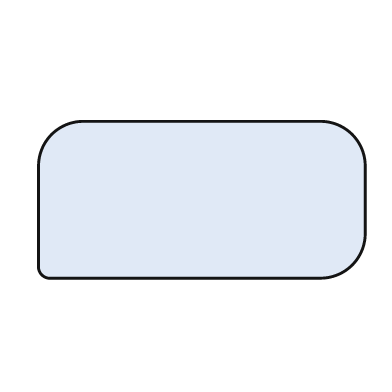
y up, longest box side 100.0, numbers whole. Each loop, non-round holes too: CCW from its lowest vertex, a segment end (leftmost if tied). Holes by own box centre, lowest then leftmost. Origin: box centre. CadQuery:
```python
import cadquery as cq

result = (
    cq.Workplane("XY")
    .moveTo(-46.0, -24.0)
    .lineTo(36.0, -24.0)
    .threePointArc((46.0, -20.0), (50.0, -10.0))
    .lineTo(50.0, 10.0)
    .threePointArc((46.0, 20.0), (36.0, 24.0))
    .lineTo(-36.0, 24.0)
    .threePointArc((-46.0, 20.0), (-50.0, 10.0))
    .lineTo(-50.0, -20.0)
    .threePointArc((-49.0, -23.0), (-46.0, -24.0))
    .close()
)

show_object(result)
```